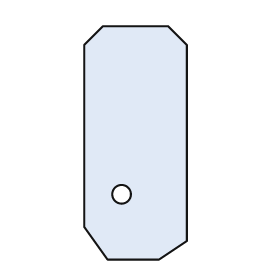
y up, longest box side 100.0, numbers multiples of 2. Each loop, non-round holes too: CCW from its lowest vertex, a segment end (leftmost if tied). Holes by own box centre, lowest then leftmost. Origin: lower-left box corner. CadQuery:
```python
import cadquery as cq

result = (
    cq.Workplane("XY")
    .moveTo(10.0, 0.0)
    .lineTo(32.0, 0.0)
    .lineTo(44.0, 8.0)
    .lineTo(44.0, 92.0)
    .lineTo(36.0, 100.0)
    .lineTo(8.0, 100.0)
    .lineTo(0.0, 92.0)
    .lineTo(0.0, 14.0)
    .close()
    .moveTo(16.0, 28.0)
    .circle(4.0)
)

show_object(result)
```